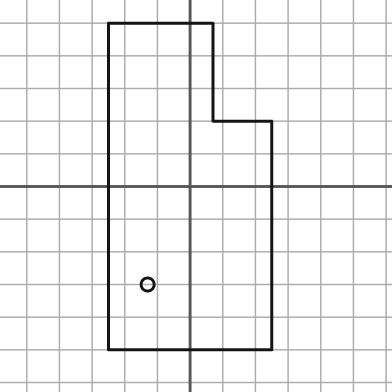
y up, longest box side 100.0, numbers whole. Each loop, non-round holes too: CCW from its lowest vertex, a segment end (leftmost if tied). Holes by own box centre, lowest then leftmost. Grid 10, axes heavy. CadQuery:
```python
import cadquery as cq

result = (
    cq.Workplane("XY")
    .moveTo(-25.0, -50.0)
    .lineTo(25.0, -50.0)
    .lineTo(25.0, 20.0)
    .lineTo(7.0, 20.0)
    .lineTo(7.0, 50.0)
    .lineTo(-25.0, 50.0)
    .close()
    .moveTo(-13.0, -30.0)
    .circle(2.0)
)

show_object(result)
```